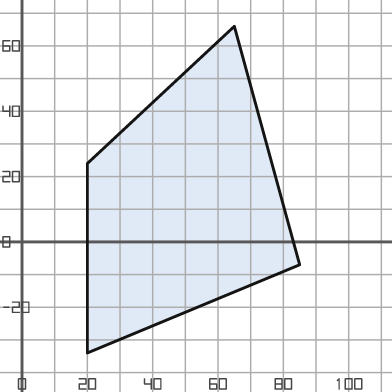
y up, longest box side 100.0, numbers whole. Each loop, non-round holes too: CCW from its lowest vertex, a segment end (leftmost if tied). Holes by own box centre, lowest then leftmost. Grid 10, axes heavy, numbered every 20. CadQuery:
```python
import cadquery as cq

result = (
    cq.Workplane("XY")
    .moveTo(20.0, -34.0)
    .lineTo(85.0, -7.0)
    .lineTo(65.0, 66.0)
    .lineTo(20.0, 24.0)
    .close()
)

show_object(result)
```